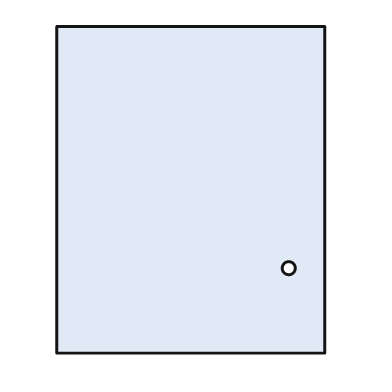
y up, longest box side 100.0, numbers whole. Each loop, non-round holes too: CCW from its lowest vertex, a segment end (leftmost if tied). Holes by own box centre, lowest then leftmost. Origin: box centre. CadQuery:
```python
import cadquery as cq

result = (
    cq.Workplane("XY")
    .moveTo(-41.0, -50.0)
    .lineTo(41.0, -50.0)
    .lineTo(41.0, 50.0)
    .lineTo(-41.0, 50.0)
    .close()
    .moveTo(30.0, -24.0)
    .circle(2.0)
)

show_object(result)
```